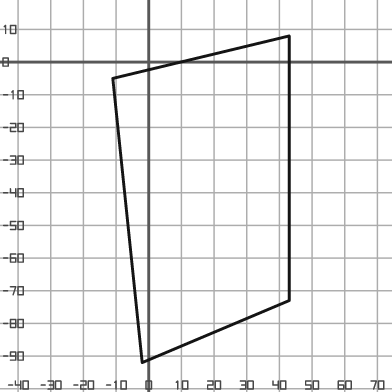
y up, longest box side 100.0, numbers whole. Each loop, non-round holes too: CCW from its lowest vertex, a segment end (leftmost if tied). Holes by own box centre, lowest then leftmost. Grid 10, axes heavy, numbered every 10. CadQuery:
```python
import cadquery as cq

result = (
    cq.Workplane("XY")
    .moveTo(-2.0, -92.0)
    .lineTo(43.0, -73.0)
    .lineTo(43.0, 8.0)
    .lineTo(-11.0, -5.0)
    .close()
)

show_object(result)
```